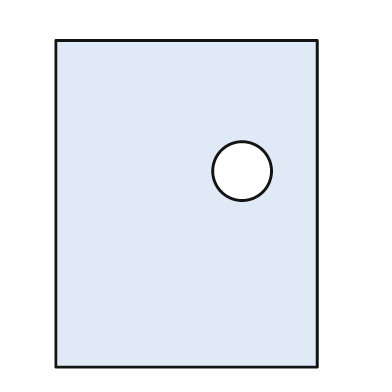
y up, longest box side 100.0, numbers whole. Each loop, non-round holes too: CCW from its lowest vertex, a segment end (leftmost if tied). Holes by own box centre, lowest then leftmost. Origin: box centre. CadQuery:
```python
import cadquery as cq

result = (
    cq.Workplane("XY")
    .moveTo(-40.0, -50.0)
    .lineTo(40.0, -50.0)
    .lineTo(40.0, 50.0)
    .lineTo(-40.0, 50.0)
    .close()
    .moveTo(17.0, 10.0)
    .circle(9.0)
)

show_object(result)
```